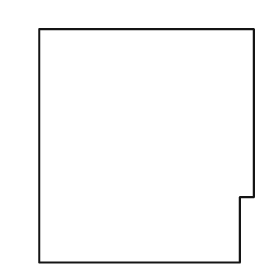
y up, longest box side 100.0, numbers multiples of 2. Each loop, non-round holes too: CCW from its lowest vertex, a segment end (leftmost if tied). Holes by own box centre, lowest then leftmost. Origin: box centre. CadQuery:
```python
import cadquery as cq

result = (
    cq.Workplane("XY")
    .moveTo(-46.0, -50.0)
    .lineTo(40.0, -50.0)
    .lineTo(40.0, -22.0)
    .lineTo(46.0, -22.0)
    .lineTo(46.0, 50.0)
    .lineTo(-46.0, 50.0)
    .close()
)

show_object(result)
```